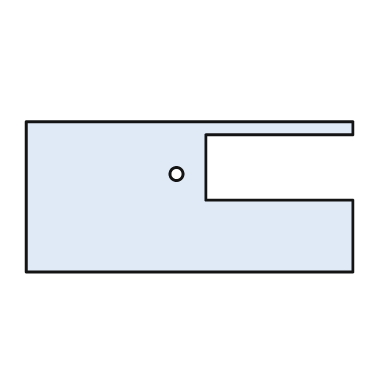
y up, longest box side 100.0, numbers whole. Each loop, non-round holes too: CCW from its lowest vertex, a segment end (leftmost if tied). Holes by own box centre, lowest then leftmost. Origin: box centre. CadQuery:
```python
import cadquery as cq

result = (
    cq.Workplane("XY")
    .moveTo(-50.0, -23.0)
    .lineTo(50.0, -23.0)
    .lineTo(50.0, -1.0)
    .lineTo(5.0, -1.0)
    .lineTo(5.0, 19.0)
    .lineTo(50.0, 19.0)
    .lineTo(50.0, 23.0)
    .lineTo(-50.0, 23.0)
    .close()
    .moveTo(-4.0, 7.0)
    .circle(2.0)
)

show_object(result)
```